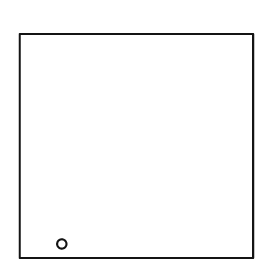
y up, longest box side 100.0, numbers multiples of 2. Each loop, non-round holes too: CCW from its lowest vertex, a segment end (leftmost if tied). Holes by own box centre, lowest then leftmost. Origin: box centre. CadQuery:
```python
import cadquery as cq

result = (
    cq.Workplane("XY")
    .moveTo(-50.0, -48.0)
    .lineTo(50.0, -48.0)
    .lineTo(50.0, 48.0)
    .lineTo(-50.0, 48.0)
    .close()
    .moveTo(-32.0, -42.0)
    .circle(2.0)
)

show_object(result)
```